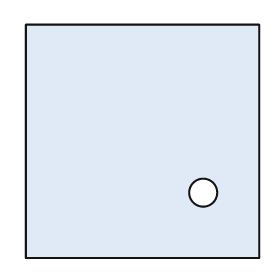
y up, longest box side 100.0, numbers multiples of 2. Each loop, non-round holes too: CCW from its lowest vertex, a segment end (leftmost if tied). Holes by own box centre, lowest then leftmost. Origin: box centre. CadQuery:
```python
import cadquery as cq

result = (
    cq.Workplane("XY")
    .moveTo(-50.0, -50.0)
    .lineTo(50.0, -50.0)
    .lineTo(50.0, 50.0)
    .lineTo(-50.0, 50.0)
    .close()
    .moveTo(26.0, -22.0)
    .circle(6.0)
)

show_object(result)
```